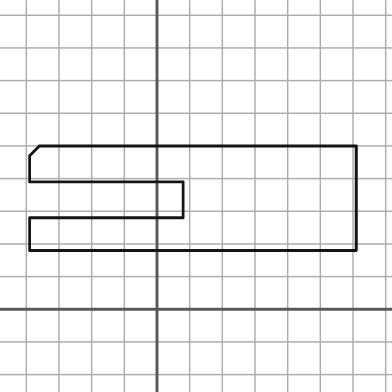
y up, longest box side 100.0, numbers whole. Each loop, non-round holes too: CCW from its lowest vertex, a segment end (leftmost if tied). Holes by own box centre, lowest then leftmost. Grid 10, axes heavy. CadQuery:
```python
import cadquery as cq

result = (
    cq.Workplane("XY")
    .moveTo(-39.0, 18.0)
    .lineTo(61.0, 18.0)
    .lineTo(61.0, 50.0)
    .lineTo(-36.0, 50.0)
    .lineTo(-39.0, 47.0)
    .lineTo(-39.0, 39.0)
    .lineTo(8.0, 39.0)
    .lineTo(8.0, 28.0)
    .lineTo(-39.0, 28.0)
    .close()
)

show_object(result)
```